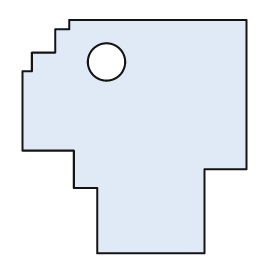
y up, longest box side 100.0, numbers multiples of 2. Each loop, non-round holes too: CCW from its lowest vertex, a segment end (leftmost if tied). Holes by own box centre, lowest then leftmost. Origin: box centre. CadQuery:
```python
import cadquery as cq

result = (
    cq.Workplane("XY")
    .moveTo(-16.0, -50.0)
    .lineTo(30.0, -50.0)
    .lineTo(30.0, -14.0)
    .lineTo(48.0, -14.0)
    .lineTo(48.0, 50.0)
    .lineTo(-28.0, 50.0)
    .lineTo(-28.0, 46.0)
    .lineTo(-34.0, 46.0)
    .lineTo(-34.0, 36.0)
    .lineTo(-44.0, 36.0)
    .lineTo(-44.0, 28.0)
    .lineTo(-48.0, 28.0)
    .lineTo(-48.0, -6.0)
    .lineTo(-26.0, -6.0)
    .lineTo(-26.0, -22.0)
    .lineTo(-16.0, -22.0)
    .close()
    .moveTo(-12.0, 32.0)
    .circle(8.0)
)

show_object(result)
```